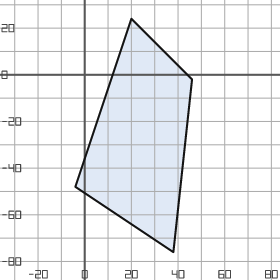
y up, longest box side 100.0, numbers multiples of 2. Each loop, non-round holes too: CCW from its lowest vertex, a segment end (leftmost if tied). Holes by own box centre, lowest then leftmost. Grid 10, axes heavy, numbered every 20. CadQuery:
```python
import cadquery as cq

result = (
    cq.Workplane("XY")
    .moveTo(38.0, -76.0)
    .lineTo(46.0, -2.0)
    .lineTo(20.0, 24.0)
    .lineTo(-4.0, -48.0)
    .close()
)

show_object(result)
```